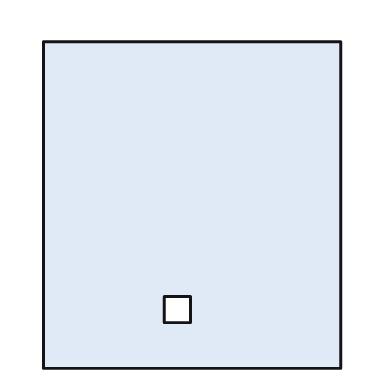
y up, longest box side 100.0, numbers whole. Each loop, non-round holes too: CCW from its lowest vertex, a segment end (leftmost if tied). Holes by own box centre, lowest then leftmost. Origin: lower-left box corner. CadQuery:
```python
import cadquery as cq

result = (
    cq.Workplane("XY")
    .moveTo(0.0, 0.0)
    .lineTo(91.0, 0.0)
    .lineTo(91.0, 100.0)
    .lineTo(0.0, 100.0)
    .close()
    .moveTo(37.0, 14.0)
    .lineTo(45.0, 14.0)
    .lineTo(45.0, 22.0)
    .lineTo(37.0, 22.0)
    .close()
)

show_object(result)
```